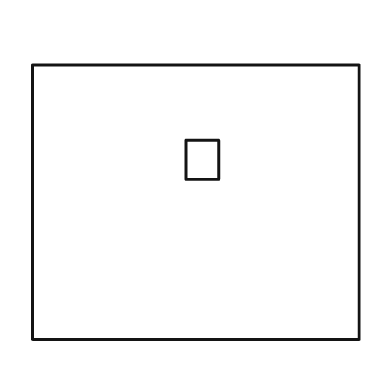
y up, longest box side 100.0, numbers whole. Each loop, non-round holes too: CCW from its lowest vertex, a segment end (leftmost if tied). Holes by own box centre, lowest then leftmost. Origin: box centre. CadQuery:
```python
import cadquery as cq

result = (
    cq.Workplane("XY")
    .moveTo(-50.0, -42.0)
    .lineTo(50.0, -42.0)
    .lineTo(50.0, 42.0)
    .lineTo(-50.0, 42.0)
    .close()
    .moveTo(-3.0, 7.0)
    .lineTo(7.0, 7.0)
    .lineTo(7.0, 19.0)
    .lineTo(-3.0, 19.0)
    .close()
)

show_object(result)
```